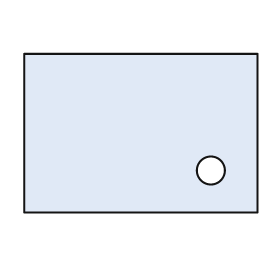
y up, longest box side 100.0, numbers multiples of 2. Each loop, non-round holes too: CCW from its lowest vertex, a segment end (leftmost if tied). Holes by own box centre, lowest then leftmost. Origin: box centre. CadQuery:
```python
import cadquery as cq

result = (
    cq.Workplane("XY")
    .moveTo(-50.0, -34.0)
    .lineTo(50.0, -34.0)
    .lineTo(50.0, 34.0)
    .lineTo(-50.0, 34.0)
    .close()
    .moveTo(30.0, -16.0)
    .circle(6.0)
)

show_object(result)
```